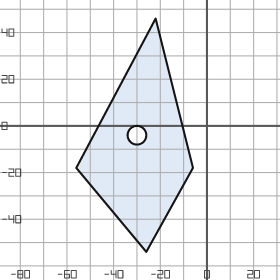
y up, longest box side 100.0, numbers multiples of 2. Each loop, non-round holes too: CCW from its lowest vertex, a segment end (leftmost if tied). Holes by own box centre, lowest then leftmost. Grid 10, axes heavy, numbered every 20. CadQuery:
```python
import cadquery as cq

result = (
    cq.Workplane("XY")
    .moveTo(-26.0, -54.0)
    .lineTo(-6.0, -18.0)
    .lineTo(-22.0, 46.0)
    .lineTo(-56.0, -18.0)
    .close()
    .moveTo(-30.0, -4.0)
    .circle(4.0)
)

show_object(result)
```